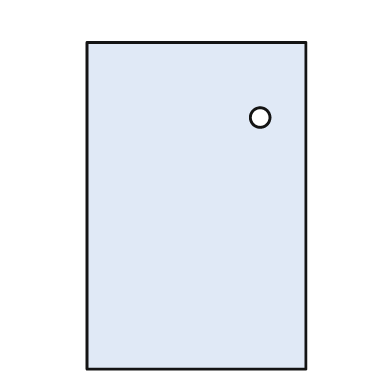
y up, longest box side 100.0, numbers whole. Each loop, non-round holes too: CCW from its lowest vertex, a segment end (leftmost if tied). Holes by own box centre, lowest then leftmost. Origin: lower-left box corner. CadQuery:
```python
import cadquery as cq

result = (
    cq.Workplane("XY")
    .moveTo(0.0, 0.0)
    .lineTo(67.0, 0.0)
    .lineTo(67.0, 100.0)
    .lineTo(0.0, 100.0)
    .close()
    .moveTo(53.0, 77.0)
    .circle(3.0)
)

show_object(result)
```